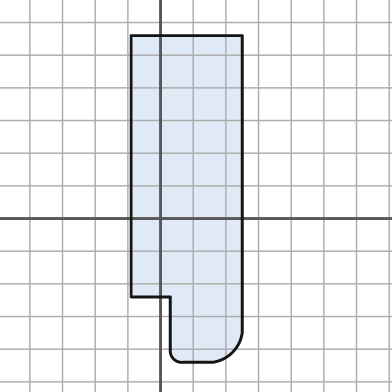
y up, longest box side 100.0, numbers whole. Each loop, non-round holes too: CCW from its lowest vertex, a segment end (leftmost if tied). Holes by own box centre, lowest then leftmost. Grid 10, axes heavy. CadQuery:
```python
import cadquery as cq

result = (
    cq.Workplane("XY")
    .moveTo(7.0, -44.0)
    .lineTo(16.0, -44.0)
    .threePointArc((22.0, -41.0), (25.0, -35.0))
    .lineTo(25.0, 56.0)
    .lineTo(-9.0, 56.0)
    .lineTo(-9.0, -24.0)
    .lineTo(3.0, -24.0)
    .lineTo(3.0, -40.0)
    .threePointArc((4.0, -43.0), (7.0, -44.0))
    .close()
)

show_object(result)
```